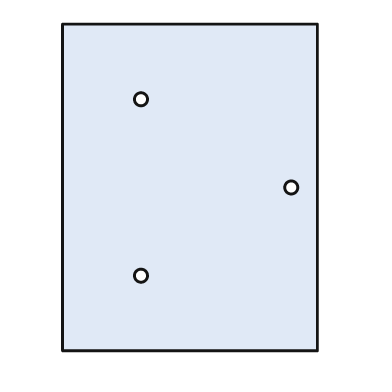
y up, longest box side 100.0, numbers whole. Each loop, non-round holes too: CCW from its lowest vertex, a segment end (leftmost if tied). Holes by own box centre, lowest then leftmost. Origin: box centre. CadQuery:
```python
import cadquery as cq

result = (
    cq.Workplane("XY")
    .moveTo(-39.0, -50.0)
    .lineTo(39.0, -50.0)
    .lineTo(39.0, 50.0)
    .lineTo(-39.0, 50.0)
    .close()
    .moveTo(-15.0, -27.0)
    .circle(2.0)
    .moveTo(31.0, 0.0)
    .circle(2.0)
    .moveTo(-15.0, 27.0)
    .circle(2.0)
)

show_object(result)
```